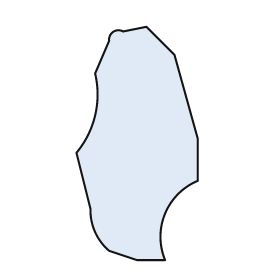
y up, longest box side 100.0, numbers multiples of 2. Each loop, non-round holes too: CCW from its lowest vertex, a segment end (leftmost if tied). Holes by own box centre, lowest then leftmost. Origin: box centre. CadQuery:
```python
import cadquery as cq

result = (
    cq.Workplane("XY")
    .moveTo(0.0, -50.0)
    .lineTo(12.0, -50.0)
    .threePointArc((12.0, -30.0), (26.0, -16.0))
    .lineTo(26.0, 2.0)
    .lineTo(16.0, 38.0)
    .lineTo(4.0, 50.0)
    .lineTo(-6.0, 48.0)
    .threePointArc((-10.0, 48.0), (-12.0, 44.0))
    .lineTo(-18.0, 30.0)
    .threePointArc((-18.0, 12.0), (-26.0, -4.0))
    .lineTo(-20.0, -28.0)
    .threePointArc((-18.0, -38.0), (-12.0, -46.0))
    .close()
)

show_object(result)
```